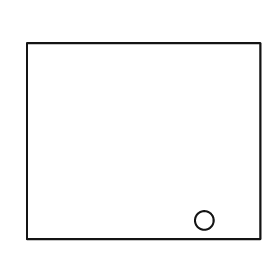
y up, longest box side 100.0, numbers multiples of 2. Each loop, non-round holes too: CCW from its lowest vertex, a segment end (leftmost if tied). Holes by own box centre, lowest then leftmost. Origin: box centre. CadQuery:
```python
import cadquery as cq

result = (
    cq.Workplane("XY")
    .moveTo(-50.0, -42.0)
    .lineTo(50.0, -42.0)
    .lineTo(50.0, 42.0)
    .lineTo(-50.0, 42.0)
    .close()
    .moveTo(26.0, -34.0)
    .circle(4.0)
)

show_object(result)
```